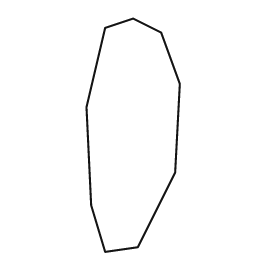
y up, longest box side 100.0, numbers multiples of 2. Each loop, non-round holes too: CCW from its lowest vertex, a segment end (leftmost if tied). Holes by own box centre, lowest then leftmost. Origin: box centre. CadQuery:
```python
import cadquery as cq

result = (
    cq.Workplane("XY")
    .moveTo(-12.0, -50.0)
    .lineTo(2.0, -48.0)
    .lineTo(18.0, -16.0)
    .lineTo(20.0, 22.0)
    .lineTo(12.0, 44.0)
    .lineTo(0.0, 50.0)
    .lineTo(-12.0, 46.0)
    .lineTo(-20.0, 12.0)
    .lineTo(-18.0, -30.0)
    .close()
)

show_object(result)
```